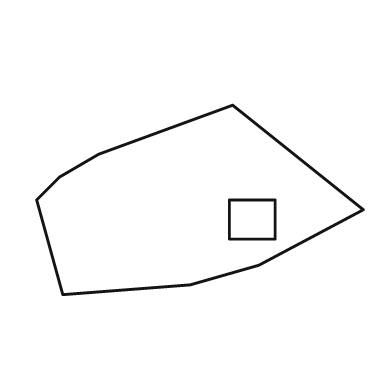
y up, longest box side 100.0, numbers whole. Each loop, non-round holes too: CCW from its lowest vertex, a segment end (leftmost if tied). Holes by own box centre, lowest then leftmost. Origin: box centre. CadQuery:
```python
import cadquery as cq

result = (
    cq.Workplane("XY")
    .moveTo(-42.0, -29.0)
    .lineTo(-3.0, -26.0)
    .lineTo(18.0, -20.0)
    .lineTo(50.0, -3.0)
    .lineTo(10.0, 29.0)
    .lineTo(-31.0, 14.0)
    .lineTo(-43.0, 7.0)
    .lineTo(-50.0, 0.0)
    .close()
    .moveTo(9.0, -12.0)
    .lineTo(23.0, -12.0)
    .lineTo(23.0, 0.0)
    .lineTo(9.0, 0.0)
    .close()
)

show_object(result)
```